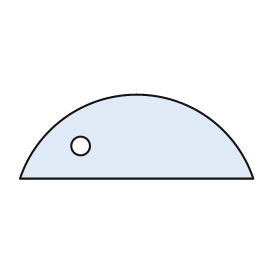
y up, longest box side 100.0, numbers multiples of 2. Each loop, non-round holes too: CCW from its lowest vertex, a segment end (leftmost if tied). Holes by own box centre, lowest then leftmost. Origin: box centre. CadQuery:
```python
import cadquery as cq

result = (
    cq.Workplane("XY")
    .moveTo(-50.0, -18.0)
    .lineTo(50.0, -18.0)
    .threePointArc((0.0, 18.0), (-50.0, -18.0))
    .close()
    .moveTo(-24.0, -4.0)
    .circle(4.0)
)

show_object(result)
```